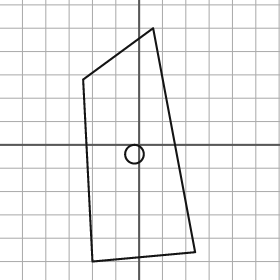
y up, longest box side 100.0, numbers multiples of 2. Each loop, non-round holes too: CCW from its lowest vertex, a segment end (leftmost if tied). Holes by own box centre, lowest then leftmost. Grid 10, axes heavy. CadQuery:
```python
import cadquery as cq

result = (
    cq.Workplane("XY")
    .moveTo(-20.0, -50.0)
    .lineTo(24.0, -46.0)
    .lineTo(6.0, 50.0)
    .lineTo(-24.0, 28.0)
    .close()
    .moveTo(-2.0, -4.0)
    .circle(4.0)
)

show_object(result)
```